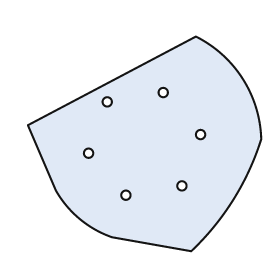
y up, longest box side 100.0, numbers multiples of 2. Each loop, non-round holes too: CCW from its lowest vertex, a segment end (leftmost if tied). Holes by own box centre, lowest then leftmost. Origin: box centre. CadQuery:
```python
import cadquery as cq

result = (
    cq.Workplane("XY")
    .moveTo(20.0, -46.0)
    .threePointArc((38.0, -24.0), (50.0, 2.0))
    .threePointArc((42.0, 28.0), (22.0, 46.0))
    .lineTo(-50.0, 8.0)
    .lineTo(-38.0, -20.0)
    .threePointArc((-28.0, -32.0), (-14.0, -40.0))
    .close()
    .moveTo(-8.0, -22.0)
    .circle(2.0)
    .moveTo(16.0, -18.0)
    .circle(2.0)
    .moveTo(-24.0, -4.0)
    .circle(2.0)
    .moveTo(24.0, 4.0)
    .circle(2.0)
    .moveTo(-16.0, 18.0)
    .circle(2.0)
    .moveTo(8.0, 22.0)
    .circle(2.0)
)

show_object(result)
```